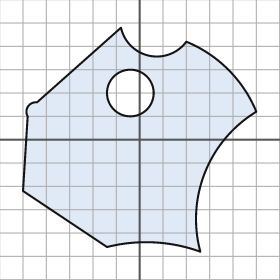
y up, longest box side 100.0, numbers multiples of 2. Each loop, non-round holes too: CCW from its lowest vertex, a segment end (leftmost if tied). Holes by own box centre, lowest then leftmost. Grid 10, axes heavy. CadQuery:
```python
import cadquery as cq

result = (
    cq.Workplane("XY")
    .moveTo(26.0, -48.0)
    .threePointArc((28.0, -14.0), (50.0, 12.0))
    .threePointArc((38.0, 30.0), (20.0, 42.0))
    .threePointArc((4.0, 36.0), (-8.0, 48.0))
    .lineTo(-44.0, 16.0)
    .threePointArc((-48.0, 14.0), (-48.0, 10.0))
    .lineTo(-50.0, -22.0)
    .lineTo(-14.0, -46.0)
    .threePointArc((6.0, -44.0), (26.0, -48.0))
    .close()
    .moveTo(-4.0, 20.0)
    .circle(10.0)
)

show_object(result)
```